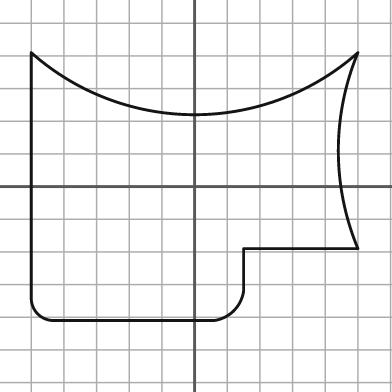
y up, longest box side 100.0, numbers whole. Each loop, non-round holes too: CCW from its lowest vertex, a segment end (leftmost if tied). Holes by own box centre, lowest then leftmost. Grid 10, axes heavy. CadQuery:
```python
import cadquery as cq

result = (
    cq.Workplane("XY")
    .moveTo(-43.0, -41.0)
    .lineTo(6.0, -41.0)
    .threePointArc((12.0, -38.0), (15.0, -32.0))
    .lineTo(15.0, -19.0)
    .lineTo(50.0, -19.0)
    .threePointArc((44.0, 11.0), (50.0, 41.0))
    .threePointArc((0.0, 22.0), (-50.0, 41.0))
    .lineTo(-50.0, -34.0)
    .threePointArc((-48.0, -39.0), (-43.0, -41.0))
    .close()
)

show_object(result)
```